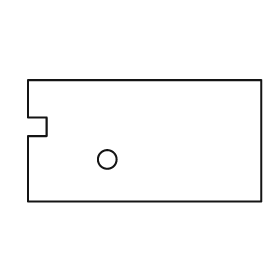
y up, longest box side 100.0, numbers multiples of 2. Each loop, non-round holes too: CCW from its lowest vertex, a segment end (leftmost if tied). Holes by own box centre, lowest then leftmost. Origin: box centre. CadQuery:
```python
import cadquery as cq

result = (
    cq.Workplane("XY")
    .moveTo(-50.0, -26.0)
    .lineTo(50.0, -26.0)
    .lineTo(50.0, 26.0)
    .lineTo(-50.0, 26.0)
    .lineTo(-50.0, 10.0)
    .lineTo(-42.0, 10.0)
    .lineTo(-42.0, 2.0)
    .lineTo(-50.0, 2.0)
    .close()
    .moveTo(-16.0, -8.0)
    .circle(4.0)
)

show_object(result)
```